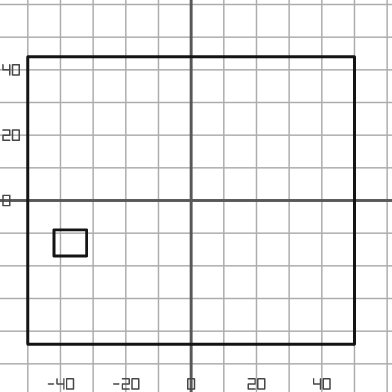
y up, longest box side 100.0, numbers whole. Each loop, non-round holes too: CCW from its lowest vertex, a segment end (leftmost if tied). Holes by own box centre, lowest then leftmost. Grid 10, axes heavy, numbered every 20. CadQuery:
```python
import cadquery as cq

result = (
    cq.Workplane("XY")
    .moveTo(-50.0, -44.0)
    .lineTo(50.0, -44.0)
    .lineTo(50.0, 44.0)
    .lineTo(-50.0, 44.0)
    .close()
    .moveTo(-42.0, -17.0)
    .lineTo(-32.0, -17.0)
    .lineTo(-32.0, -9.0)
    .lineTo(-42.0, -9.0)
    .close()
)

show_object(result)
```